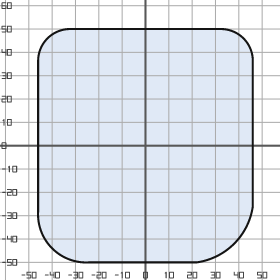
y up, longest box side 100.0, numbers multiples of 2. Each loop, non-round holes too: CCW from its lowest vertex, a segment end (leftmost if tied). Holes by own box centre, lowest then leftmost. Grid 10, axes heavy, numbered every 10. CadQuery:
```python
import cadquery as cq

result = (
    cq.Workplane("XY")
    .moveTo(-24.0, -50.0)
    .lineTo(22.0, -50.0)
    .threePointArc((38.0, -42.0), (46.0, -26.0))
    .lineTo(46.0, 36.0)
    .threePointArc((42.0, 46.0), (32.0, 50.0))
    .lineTo(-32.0, 50.0)
    .threePointArc((-42.0, 46.0), (-46.0, 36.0))
    .lineTo(-46.0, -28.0)
    .threePointArc((-40.0, -44.0), (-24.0, -50.0))
    .close()
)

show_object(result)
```